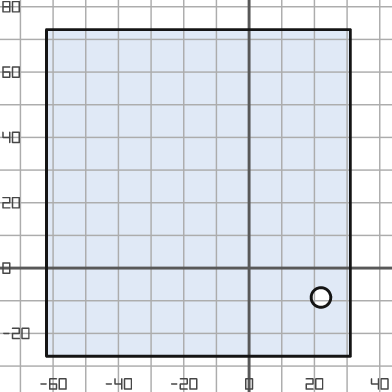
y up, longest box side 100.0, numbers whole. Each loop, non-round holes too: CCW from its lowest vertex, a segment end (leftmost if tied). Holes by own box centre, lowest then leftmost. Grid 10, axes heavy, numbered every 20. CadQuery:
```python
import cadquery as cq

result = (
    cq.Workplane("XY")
    .moveTo(-62.0, -27.0)
    .lineTo(31.0, -27.0)
    .lineTo(31.0, 73.0)
    .lineTo(-62.0, 73.0)
    .close()
    .moveTo(22.0, -9.0)
    .circle(3.0)
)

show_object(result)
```